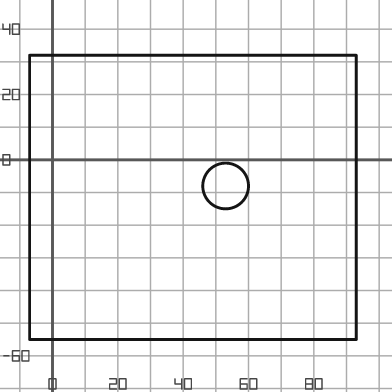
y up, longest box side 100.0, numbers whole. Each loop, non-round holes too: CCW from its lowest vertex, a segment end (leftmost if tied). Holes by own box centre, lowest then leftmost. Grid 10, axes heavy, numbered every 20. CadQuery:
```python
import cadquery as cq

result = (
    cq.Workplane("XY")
    .moveTo(-7.0, -55.0)
    .lineTo(93.0, -55.0)
    .lineTo(93.0, 32.0)
    .lineTo(-7.0, 32.0)
    .close()
    .moveTo(53.0, -8.0)
    .circle(7.0)
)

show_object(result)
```